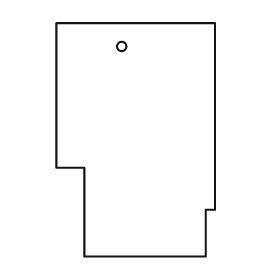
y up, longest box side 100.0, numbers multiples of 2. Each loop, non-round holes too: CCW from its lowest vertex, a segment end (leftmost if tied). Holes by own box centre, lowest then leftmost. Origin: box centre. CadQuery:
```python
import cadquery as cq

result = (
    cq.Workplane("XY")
    .moveTo(-22.0, -50.0)
    .lineTo(30.0, -50.0)
    .lineTo(30.0, -30.0)
    .lineTo(34.0, -30.0)
    .lineTo(34.0, 50.0)
    .lineTo(-34.0, 50.0)
    .lineTo(-34.0, -12.0)
    .lineTo(-22.0, -12.0)
    .close()
    .moveTo(-6.0, 40.0)
    .circle(2.0)
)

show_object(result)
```